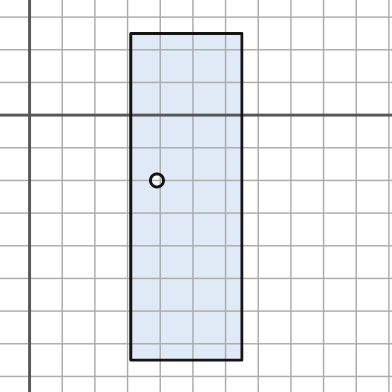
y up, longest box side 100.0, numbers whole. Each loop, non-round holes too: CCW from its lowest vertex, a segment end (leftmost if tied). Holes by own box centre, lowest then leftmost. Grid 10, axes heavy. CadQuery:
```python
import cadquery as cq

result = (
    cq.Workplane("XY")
    .moveTo(31.0, -75.0)
    .lineTo(65.0, -75.0)
    .lineTo(65.0, 25.0)
    .lineTo(31.0, 25.0)
    .close()
    .moveTo(39.0, -20.0)
    .circle(2.0)
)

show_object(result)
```